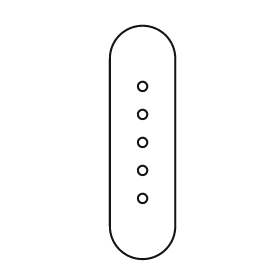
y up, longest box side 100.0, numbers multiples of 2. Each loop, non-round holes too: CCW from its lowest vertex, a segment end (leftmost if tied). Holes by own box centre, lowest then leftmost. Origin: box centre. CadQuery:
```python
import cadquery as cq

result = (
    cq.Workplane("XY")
    .moveTo(-14.0, -36.0)
    .threePointArc((0.0, -50.0), (14.0, -36.0))
    .lineTo(14.0, 36.0)
    .threePointArc((0.0, 50.0), (-14.0, 36.0))
    .close()
    .moveTo(0.0, -24.0)
    .circle(2.0)
    .moveTo(0.0, -12.0)
    .circle(2.0)
    .moveTo(0.0, 0.0)
    .circle(2.0)
    .moveTo(0.0, 12.0)
    .circle(2.0)
    .moveTo(0.0, 24.0)
    .circle(2.0)
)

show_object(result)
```